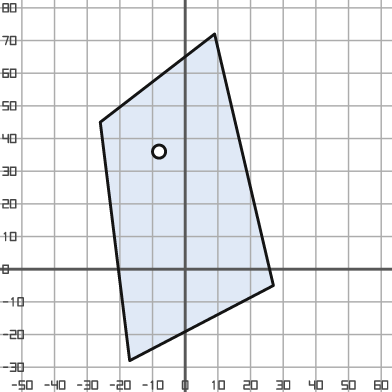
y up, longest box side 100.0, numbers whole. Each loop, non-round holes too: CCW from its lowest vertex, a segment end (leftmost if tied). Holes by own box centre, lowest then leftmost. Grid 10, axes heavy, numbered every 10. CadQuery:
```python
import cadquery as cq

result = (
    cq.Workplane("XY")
    .moveTo(-17.0, -28.0)
    .lineTo(27.0, -5.0)
    .lineTo(9.0, 72.0)
    .lineTo(-26.0, 45.0)
    .close()
    .moveTo(-8.0, 36.0)
    .circle(2.0)
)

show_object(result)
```